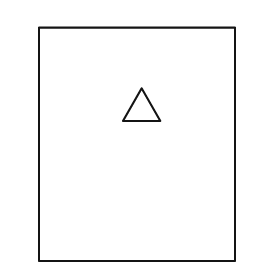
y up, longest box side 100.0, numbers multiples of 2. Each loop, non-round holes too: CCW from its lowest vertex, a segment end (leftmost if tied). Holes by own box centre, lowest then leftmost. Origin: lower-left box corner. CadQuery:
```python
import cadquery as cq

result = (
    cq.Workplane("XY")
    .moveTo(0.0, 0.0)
    .lineTo(84.0, 0.0)
    .lineTo(84.0, 100.0)
    .lineTo(0.0, 100.0)
    .close()
    .moveTo(36.0, 60.0)
    .lineTo(52.0, 60.0)
    .lineTo(44.0, 74.0)
    .close()
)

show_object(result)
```